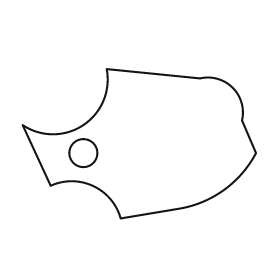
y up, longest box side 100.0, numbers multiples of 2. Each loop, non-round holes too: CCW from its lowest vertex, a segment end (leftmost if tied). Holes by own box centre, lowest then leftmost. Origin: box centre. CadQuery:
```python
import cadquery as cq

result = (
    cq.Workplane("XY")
    .moveTo(-8.0, -32.0)
    .lineTo(16.0, -28.0)
    .threePointArc((36.0, -20.0), (50.0, -4.0))
    .lineTo(44.0, 10.0)
    .threePointArc((40.0, 24.0), (26.0, 28.0))
    .lineTo(-14.0, 32.0)
    .threePointArc((-24.0, 8.0), (-50.0, 8.0))
    .lineTo(-38.0, -18.0)
    .threePointArc((-20.0, -18.0), (-8.0, -32.0))
    .close()
    .moveTo(-24.0, -4.0)
    .circle(6.0)
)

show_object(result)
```